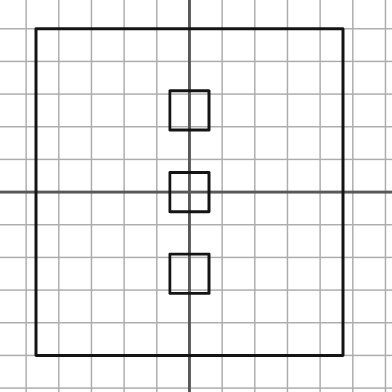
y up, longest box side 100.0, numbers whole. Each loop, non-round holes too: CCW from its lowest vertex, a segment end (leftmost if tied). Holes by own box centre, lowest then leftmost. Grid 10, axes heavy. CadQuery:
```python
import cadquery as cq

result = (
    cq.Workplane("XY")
    .moveTo(-47.0, -50.0)
    .lineTo(47.0, -50.0)
    .lineTo(47.0, 50.0)
    .lineTo(-47.0, 50.0)
    .close()
    .moveTo(-6.0, -31.0)
    .lineTo(6.0, -31.0)
    .lineTo(6.0, -19.0)
    .lineTo(-6.0, -19.0)
    .close()
    .moveTo(-6.0, -6.0)
    .lineTo(6.0, -6.0)
    .lineTo(6.0, 6.0)
    .lineTo(-6.0, 6.0)
    .close()
    .moveTo(-6.0, 19.0)
    .lineTo(6.0, 19.0)
    .lineTo(6.0, 31.0)
    .lineTo(-6.0, 31.0)
    .close()
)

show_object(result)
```